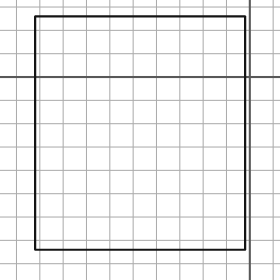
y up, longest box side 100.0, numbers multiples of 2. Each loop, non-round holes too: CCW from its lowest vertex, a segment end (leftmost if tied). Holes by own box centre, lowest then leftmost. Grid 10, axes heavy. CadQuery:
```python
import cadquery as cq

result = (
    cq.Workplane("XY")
    .moveTo(-92.0, -74.0)
    .lineTo(-2.0, -74.0)
    .lineTo(-2.0, 26.0)
    .lineTo(-92.0, 26.0)
    .close()
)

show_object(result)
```